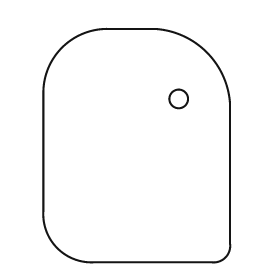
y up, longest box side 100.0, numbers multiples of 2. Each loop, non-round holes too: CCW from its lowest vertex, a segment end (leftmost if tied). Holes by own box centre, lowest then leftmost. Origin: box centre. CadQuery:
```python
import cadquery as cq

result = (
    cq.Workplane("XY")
    .moveTo(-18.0, -50.0)
    .lineTo(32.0, -50.0)
    .threePointArc((38.0, -48.0), (40.0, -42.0))
    .lineTo(40.0, 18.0)
    .threePointArc((30.0, 40.0), (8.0, 50.0))
    .lineTo(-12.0, 50.0)
    .threePointArc((-32.0, 42.0), (-40.0, 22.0))
    .lineTo(-40.0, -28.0)
    .threePointArc((-34.0, -44.0), (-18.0, -50.0))
    .close()
    .moveTo(18.0, 20.0)
    .circle(4.0)
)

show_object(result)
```